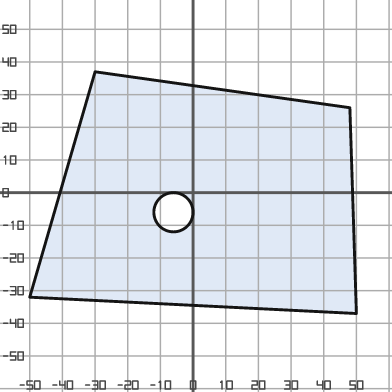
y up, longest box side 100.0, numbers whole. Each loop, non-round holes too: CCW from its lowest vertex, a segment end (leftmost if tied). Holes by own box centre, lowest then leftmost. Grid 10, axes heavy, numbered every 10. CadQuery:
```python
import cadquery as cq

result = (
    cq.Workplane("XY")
    .moveTo(50.0, -37.0)
    .lineTo(48.0, 26.0)
    .lineTo(-30.0, 37.0)
    .lineTo(-50.0, -32.0)
    .close()
    .moveTo(-6.0, -6.0)
    .circle(6.0)
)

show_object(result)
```